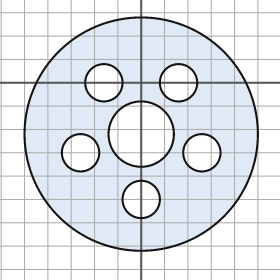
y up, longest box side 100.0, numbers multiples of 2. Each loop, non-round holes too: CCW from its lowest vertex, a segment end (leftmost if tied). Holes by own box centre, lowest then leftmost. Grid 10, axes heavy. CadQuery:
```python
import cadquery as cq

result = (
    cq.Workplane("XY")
    .moveTo(0.0, -22.0)
    .circle(50.0)
    .moveTo(0.0, -50.0)
    .circle(8.0)
    .moveTo(-26.0, -30.0)
    .circle(8.0)
    .moveTo(26.0, -30.0)
    .circle(8.0)
    .moveTo(0.0, -22.0)
    .circle(14.0)
    .moveTo(-16.0, 0.0)
    .circle(8.0)
    .moveTo(16.0, 0.0)
    .circle(8.0)
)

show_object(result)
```